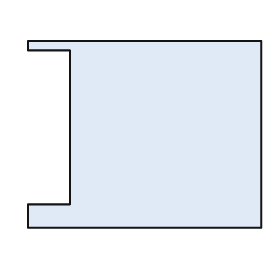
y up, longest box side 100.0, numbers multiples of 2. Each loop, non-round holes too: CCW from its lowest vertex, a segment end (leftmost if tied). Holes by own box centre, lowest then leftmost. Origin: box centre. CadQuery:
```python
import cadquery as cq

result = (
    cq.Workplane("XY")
    .moveTo(-50.0, -40.0)
    .lineTo(50.0, -40.0)
    .lineTo(50.0, 40.0)
    .lineTo(-50.0, 40.0)
    .lineTo(-50.0, 36.0)
    .lineTo(-32.0, 36.0)
    .lineTo(-32.0, -30.0)
    .lineTo(-50.0, -30.0)
    .close()
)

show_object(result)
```